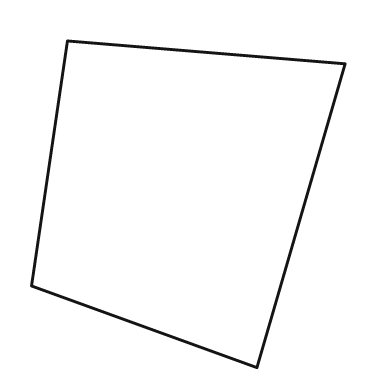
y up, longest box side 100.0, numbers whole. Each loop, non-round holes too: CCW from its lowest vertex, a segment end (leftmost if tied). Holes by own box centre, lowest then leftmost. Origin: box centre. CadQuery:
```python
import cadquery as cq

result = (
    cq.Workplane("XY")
    .moveTo(21.0, -50.0)
    .lineTo(48.0, 43.0)
    .lineTo(-37.0, 50.0)
    .lineTo(-48.0, -25.0)
    .close()
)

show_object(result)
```